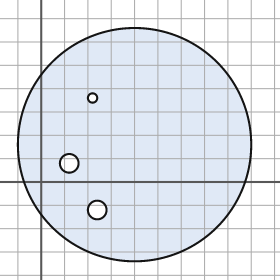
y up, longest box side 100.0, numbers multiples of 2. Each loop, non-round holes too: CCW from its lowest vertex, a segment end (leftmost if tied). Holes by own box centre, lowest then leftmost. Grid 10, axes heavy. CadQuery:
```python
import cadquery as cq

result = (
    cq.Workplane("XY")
    .moveTo(40.0, 16.0)
    .circle(50.0)
    .moveTo(24.0, -12.0)
    .circle(4.0)
    .moveTo(12.0, 8.0)
    .circle(4.0)
    .moveTo(22.0, 36.0)
    .circle(2.0)
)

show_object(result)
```